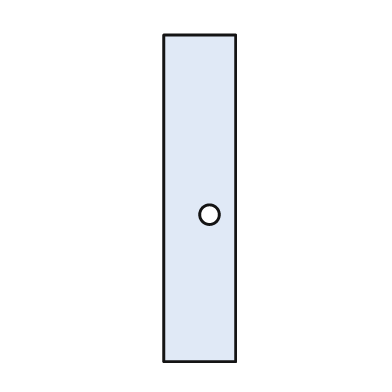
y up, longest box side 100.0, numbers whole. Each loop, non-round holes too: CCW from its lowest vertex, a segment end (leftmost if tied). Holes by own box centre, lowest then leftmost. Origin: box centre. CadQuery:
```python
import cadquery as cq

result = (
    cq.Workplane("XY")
    .moveTo(-11.0, -50.0)
    .lineTo(11.0, -50.0)
    .lineTo(11.0, 50.0)
    .lineTo(-11.0, 50.0)
    .close()
    .moveTo(3.0, -5.0)
    .circle(3.0)
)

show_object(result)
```